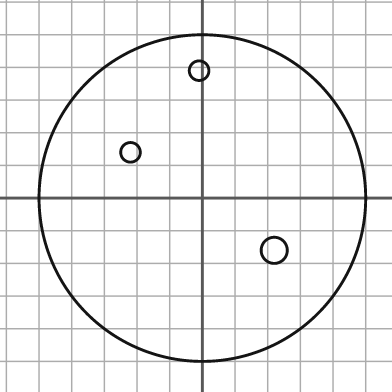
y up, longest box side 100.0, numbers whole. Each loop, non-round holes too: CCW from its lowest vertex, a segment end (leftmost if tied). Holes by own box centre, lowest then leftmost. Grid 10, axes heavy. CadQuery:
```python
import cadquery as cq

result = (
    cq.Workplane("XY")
    .moveTo(0.0, 0.0)
    .circle(50.0)
    .moveTo(22.0, -16.0)
    .circle(4.0)
    .moveTo(-22.0, 14.0)
    .circle(3.0)
    .moveTo(-1.0, 39.0)
    .circle(3.0)
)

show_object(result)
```